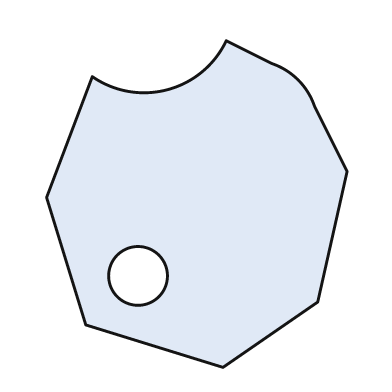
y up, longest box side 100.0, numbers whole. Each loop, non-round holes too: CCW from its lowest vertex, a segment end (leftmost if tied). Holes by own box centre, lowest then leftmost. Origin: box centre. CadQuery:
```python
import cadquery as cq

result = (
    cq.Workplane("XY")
    .moveTo(8.0, -50.0)
    .lineTo(37.0, -30.0)
    .lineTo(46.0, 10.0)
    .lineTo(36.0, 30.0)
    .threePointArc((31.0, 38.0), (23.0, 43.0))
    .lineTo(9.0, 50.0)
    .threePointArc((-9.0, 35.0), (-32.0, 39.0))
    .lineTo(-46.0, 2.0)
    .lineTo(-34.0, -37.0)
    .close()
    .moveTo(-18.0, -22.0)
    .circle(9.0)
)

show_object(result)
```